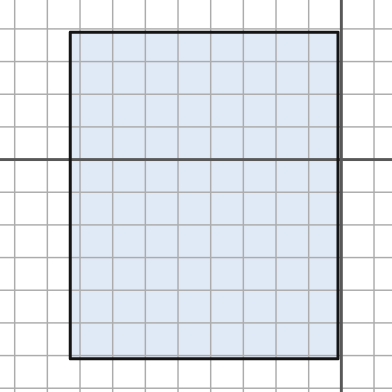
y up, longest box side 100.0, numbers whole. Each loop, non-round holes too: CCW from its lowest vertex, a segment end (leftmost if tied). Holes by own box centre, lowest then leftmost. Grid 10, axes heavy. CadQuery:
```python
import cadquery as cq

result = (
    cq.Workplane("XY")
    .moveTo(-83.0, -61.0)
    .lineTo(-1.0, -61.0)
    .lineTo(-1.0, 39.0)
    .lineTo(-83.0, 39.0)
    .close()
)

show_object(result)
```